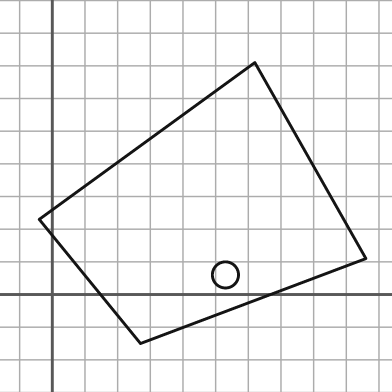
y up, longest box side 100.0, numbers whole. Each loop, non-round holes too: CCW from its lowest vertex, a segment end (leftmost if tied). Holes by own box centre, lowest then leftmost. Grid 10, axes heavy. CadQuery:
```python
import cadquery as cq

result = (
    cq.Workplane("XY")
    .moveTo(27.0, -15.0)
    .lineTo(96.0, 11.0)
    .lineTo(62.0, 71.0)
    .lineTo(-4.0, 23.0)
    .close()
    .moveTo(53.0, 6.0)
    .circle(4.0)
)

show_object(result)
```